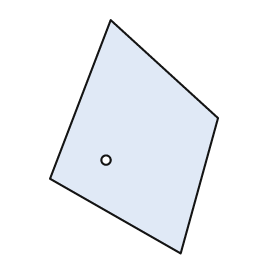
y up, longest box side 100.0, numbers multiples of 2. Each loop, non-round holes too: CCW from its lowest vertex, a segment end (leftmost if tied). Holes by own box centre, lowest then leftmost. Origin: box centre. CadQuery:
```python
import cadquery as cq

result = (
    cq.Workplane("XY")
    .moveTo(20.0, -50.0)
    .lineTo(36.0, 8.0)
    .lineTo(-10.0, 50.0)
    .lineTo(-36.0, -18.0)
    .close()
    .moveTo(-12.0, -10.0)
    .circle(2.0)
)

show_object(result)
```